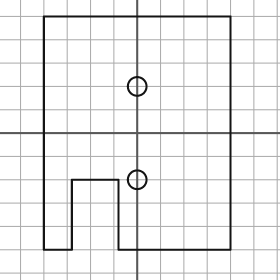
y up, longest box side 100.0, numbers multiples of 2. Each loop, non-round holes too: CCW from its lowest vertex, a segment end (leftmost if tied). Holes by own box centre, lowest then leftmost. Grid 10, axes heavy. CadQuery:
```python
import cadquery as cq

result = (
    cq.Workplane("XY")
    .moveTo(-40.0, -50.0)
    .lineTo(-28.0, -50.0)
    .lineTo(-28.0, -20.0)
    .lineTo(-8.0, -20.0)
    .lineTo(-8.0, -50.0)
    .lineTo(40.0, -50.0)
    .lineTo(40.0, 50.0)
    .lineTo(-40.0, 50.0)
    .close()
    .moveTo(0.0, -20.0)
    .circle(4.0)
    .moveTo(0.0, 20.0)
    .circle(4.0)
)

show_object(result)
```